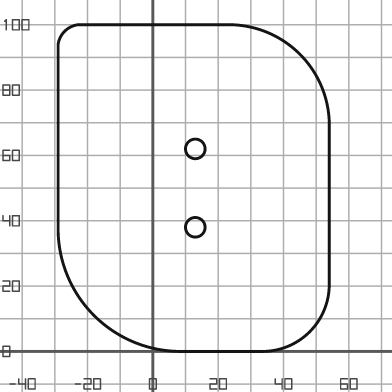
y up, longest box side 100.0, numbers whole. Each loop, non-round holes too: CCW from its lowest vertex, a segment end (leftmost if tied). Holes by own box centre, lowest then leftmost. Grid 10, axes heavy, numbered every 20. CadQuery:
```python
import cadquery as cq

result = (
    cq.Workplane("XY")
    .moveTo(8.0, 0.0)
    .lineTo(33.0, 0.0)
    .threePointArc((48.0, 6.0), (54.0, 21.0))
    .lineTo(54.0, 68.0)
    .threePointArc((45.0, 91.0), (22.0, 100.0))
    .lineTo(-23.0, 100.0)
    .threePointArc((-27.0, 98.0), (-29.0, 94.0))
    .lineTo(-29.0, 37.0)
    .threePointArc((-18.0, 11.0), (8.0, 0.0))
    .close()
    .moveTo(13.0, 38.0)
    .circle(3.0)
    .moveTo(13.0, 62.0)
    .circle(3.0)
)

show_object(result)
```